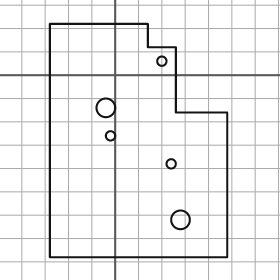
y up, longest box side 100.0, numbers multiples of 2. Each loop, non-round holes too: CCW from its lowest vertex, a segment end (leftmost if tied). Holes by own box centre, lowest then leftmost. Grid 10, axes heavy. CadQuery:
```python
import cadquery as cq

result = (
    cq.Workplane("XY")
    .moveTo(-28.0, -78.0)
    .lineTo(48.0, -78.0)
    .lineTo(48.0, -16.0)
    .lineTo(26.0, -16.0)
    .lineTo(26.0, 12.0)
    .lineTo(14.0, 12.0)
    .lineTo(14.0, 22.0)
    .lineTo(-28.0, 22.0)
    .close()
    .moveTo(28.0, -62.0)
    .circle(4.0)
    .moveTo(24.0, -38.0)
    .circle(2.0)
    .moveTo(-2.0, -26.0)
    .circle(2.0)
    .moveTo(-4.0, -14.0)
    .circle(4.0)
    .moveTo(20.0, 6.0)
    .circle(2.0)
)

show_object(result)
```